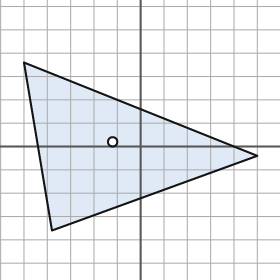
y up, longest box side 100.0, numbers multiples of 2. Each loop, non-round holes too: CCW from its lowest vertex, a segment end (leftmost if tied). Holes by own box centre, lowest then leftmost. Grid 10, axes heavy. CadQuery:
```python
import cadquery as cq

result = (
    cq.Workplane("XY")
    .moveTo(-38.0, -36.0)
    .lineTo(50.0, -4.0)
    .lineTo(-50.0, 36.0)
    .close()
    .moveTo(-12.0, 2.0)
    .circle(2.0)
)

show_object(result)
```